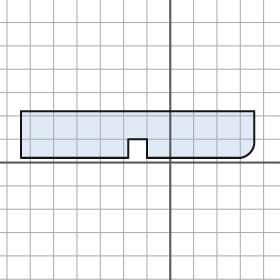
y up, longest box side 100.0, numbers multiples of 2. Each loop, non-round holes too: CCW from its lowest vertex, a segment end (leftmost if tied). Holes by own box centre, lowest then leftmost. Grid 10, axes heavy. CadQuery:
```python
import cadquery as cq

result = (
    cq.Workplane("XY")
    .moveTo(-64.0, 2.0)
    .lineTo(-18.0, 2.0)
    .lineTo(-18.0, 10.0)
    .lineTo(-10.0, 10.0)
    .lineTo(-10.0, 2.0)
    .lineTo(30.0, 2.0)
    .threePointArc((34.0, 4.0), (36.0, 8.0))
    .lineTo(36.0, 22.0)
    .lineTo(-64.0, 22.0)
    .close()
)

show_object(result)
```